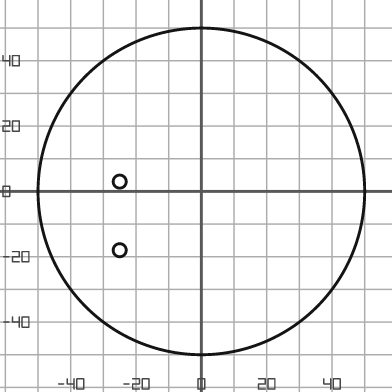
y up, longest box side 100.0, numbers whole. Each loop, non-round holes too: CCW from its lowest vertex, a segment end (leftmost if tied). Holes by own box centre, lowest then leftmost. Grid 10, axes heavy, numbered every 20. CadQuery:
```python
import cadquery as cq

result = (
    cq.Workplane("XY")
    .moveTo(0.0, 0.0)
    .circle(50.0)
    .moveTo(-25.0, -18.0)
    .circle(2.0)
    .moveTo(-25.0, 3.0)
    .circle(2.0)
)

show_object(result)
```